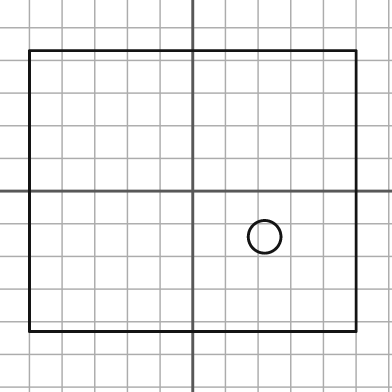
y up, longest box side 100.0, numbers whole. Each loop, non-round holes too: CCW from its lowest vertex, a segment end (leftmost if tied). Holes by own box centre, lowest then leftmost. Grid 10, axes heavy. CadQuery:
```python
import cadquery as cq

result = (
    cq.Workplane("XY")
    .moveTo(-50.0, -43.0)
    .lineTo(50.0, -43.0)
    .lineTo(50.0, 43.0)
    .lineTo(-50.0, 43.0)
    .close()
    .moveTo(22.0, -14.0)
    .circle(5.0)
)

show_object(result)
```